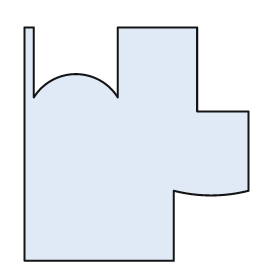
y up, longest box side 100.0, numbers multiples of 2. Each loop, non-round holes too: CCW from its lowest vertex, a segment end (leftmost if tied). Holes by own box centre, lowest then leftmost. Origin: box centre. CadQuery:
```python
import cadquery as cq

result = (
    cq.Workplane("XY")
    .moveTo(-48.0, -50.0)
    .lineTo(16.0, -50.0)
    .lineTo(16.0, -20.0)
    .threePointArc((32.0, -22.0), (48.0, -20.0))
    .lineTo(48.0, 14.0)
    .lineTo(26.0, 14.0)
    .lineTo(26.0, 50.0)
    .lineTo(-8.0, 50.0)
    .lineTo(-8.0, 20.0)
    .threePointArc((-26.0, 30.0), (-44.0, 20.0))
    .lineTo(-44.0, 50.0)
    .lineTo(-48.0, 50.0)
    .close()
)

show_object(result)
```